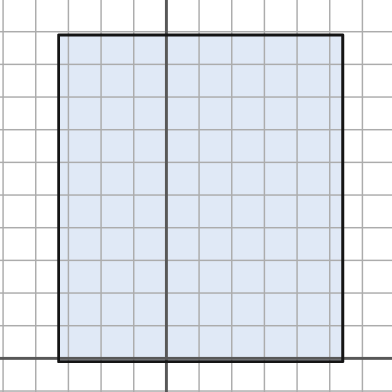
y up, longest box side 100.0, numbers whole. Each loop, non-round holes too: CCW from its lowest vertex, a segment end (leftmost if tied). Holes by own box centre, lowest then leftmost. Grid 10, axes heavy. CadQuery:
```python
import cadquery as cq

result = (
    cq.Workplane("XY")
    .moveTo(-33.0, -1.0)
    .lineTo(54.0, -1.0)
    .lineTo(54.0, 99.0)
    .lineTo(-33.0, 99.0)
    .close()
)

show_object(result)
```